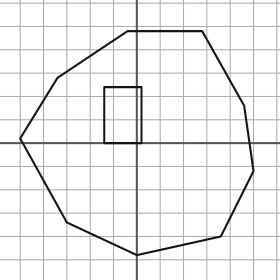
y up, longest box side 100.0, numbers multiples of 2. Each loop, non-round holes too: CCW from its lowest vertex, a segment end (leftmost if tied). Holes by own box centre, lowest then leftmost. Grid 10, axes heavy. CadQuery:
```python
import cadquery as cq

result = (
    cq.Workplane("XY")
    .moveTo(0.0, -48.0)
    .lineTo(36.0, -40.0)
    .lineTo(50.0, -12.0)
    .lineTo(46.0, 16.0)
    .lineTo(28.0, 48.0)
    .lineTo(-4.0, 48.0)
    .lineTo(-34.0, 28.0)
    .lineTo(-50.0, 2.0)
    .lineTo(-30.0, -34.0)
    .close()
    .moveTo(-14.0, 0.0)
    .lineTo(2.0, 0.0)
    .lineTo(2.0, 24.0)
    .lineTo(-14.0, 24.0)
    .close()
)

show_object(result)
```